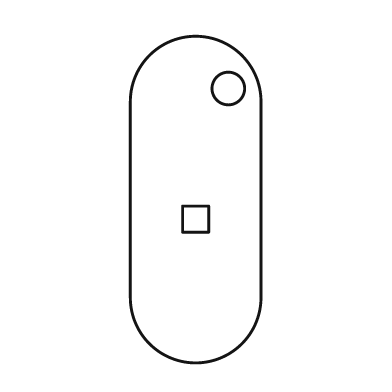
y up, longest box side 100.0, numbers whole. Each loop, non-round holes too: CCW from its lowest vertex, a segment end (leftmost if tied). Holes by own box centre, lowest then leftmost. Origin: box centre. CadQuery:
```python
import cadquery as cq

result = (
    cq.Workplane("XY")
    .moveTo(-20.0, -30.0)
    .threePointArc((0.0, -50.0), (20.0, -30.0))
    .lineTo(20.0, 30.0)
    .threePointArc((0.0, 50.0), (-20.0, 30.0))
    .close()
    .moveTo(-4.0, -10.0)
    .lineTo(4.0, -10.0)
    .lineTo(4.0, -2.0)
    .lineTo(-4.0, -2.0)
    .close()
    .moveTo(10.0, 34.0)
    .circle(5.0)
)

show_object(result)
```